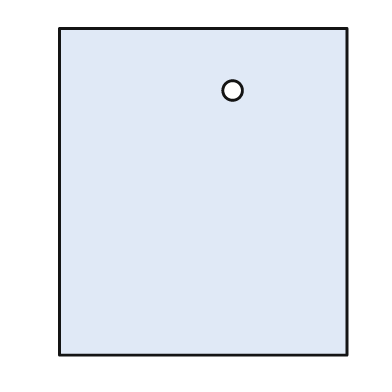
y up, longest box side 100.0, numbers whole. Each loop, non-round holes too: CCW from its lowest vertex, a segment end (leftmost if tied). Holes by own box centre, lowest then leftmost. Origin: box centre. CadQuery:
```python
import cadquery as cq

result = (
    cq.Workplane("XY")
    .moveTo(-44.0, -50.0)
    .lineTo(44.0, -50.0)
    .lineTo(44.0, 50.0)
    .lineTo(-44.0, 50.0)
    .close()
    .moveTo(9.0, 31.0)
    .circle(3.0)
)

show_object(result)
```